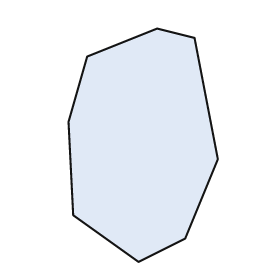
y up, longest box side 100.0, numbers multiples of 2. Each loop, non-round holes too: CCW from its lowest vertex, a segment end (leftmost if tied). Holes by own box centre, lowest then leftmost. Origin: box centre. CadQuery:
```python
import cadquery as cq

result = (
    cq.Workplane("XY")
    .moveTo(-2.0, -50.0)
    .lineTo(18.0, -40.0)
    .lineTo(32.0, -6.0)
    .lineTo(22.0, 46.0)
    .lineTo(6.0, 50.0)
    .lineTo(-24.0, 38.0)
    .lineTo(-32.0, 10.0)
    .lineTo(-30.0, -30.0)
    .close()
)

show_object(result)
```